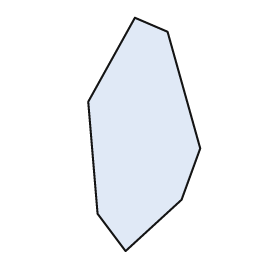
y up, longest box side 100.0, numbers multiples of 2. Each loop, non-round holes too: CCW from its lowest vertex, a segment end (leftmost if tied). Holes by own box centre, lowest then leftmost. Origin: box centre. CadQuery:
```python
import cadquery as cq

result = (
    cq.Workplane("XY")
    .moveTo(-8.0, -50.0)
    .lineTo(16.0, -28.0)
    .lineTo(24.0, -6.0)
    .lineTo(10.0, 44.0)
    .lineTo(-4.0, 50.0)
    .lineTo(-24.0, 14.0)
    .lineTo(-20.0, -34.0)
    .close()
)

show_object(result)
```